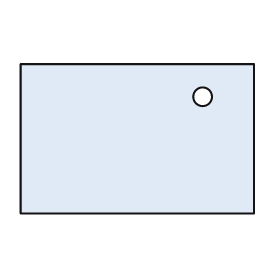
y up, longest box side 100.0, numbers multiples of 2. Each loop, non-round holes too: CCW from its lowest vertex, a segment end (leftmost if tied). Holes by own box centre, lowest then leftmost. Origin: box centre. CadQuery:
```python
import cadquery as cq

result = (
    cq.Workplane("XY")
    .moveTo(-50.0, -32.0)
    .lineTo(50.0, -32.0)
    .lineTo(50.0, 32.0)
    .lineTo(-50.0, 32.0)
    .close()
    .moveTo(28.0, 18.0)
    .circle(4.0)
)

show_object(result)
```